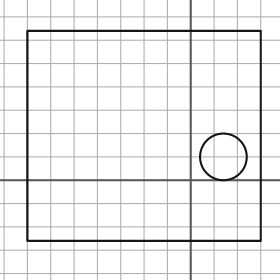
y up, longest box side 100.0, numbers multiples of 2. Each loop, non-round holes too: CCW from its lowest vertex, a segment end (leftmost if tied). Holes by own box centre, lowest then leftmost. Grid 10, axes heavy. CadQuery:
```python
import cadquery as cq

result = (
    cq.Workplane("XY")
    .moveTo(-70.0, -26.0)
    .lineTo(30.0, -26.0)
    .lineTo(30.0, 64.0)
    .lineTo(-70.0, 64.0)
    .close()
    .moveTo(14.0, 10.0)
    .circle(10.0)
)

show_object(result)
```